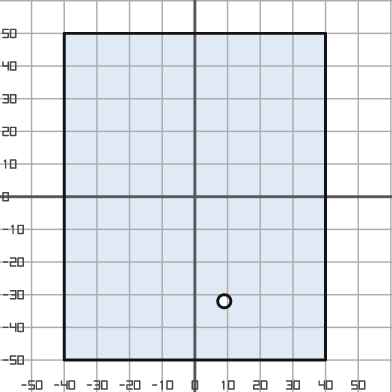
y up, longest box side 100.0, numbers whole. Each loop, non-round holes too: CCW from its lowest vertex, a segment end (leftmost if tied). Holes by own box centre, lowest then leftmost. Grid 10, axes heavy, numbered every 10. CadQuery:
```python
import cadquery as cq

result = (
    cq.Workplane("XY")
    .moveTo(-40.0, -50.0)
    .lineTo(40.0, -50.0)
    .lineTo(40.0, 50.0)
    .lineTo(-40.0, 50.0)
    .close()
    .moveTo(9.0, -32.0)
    .circle(2.0)
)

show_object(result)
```